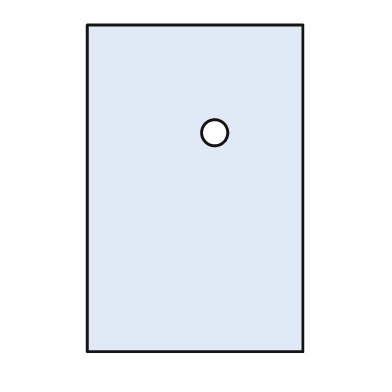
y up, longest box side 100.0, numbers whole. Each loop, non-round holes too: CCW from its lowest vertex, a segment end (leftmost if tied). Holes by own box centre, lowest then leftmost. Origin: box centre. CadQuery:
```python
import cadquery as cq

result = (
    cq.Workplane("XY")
    .moveTo(-33.0, -50.0)
    .lineTo(33.0, -50.0)
    .lineTo(33.0, 50.0)
    .lineTo(-33.0, 50.0)
    .close()
    .moveTo(6.0, 17.0)
    .circle(4.0)
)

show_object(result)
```